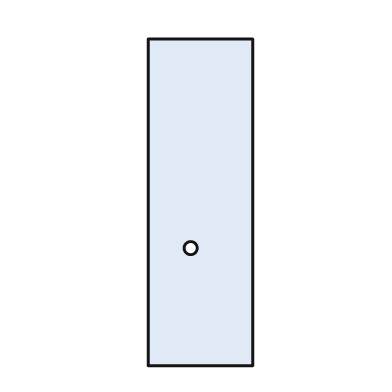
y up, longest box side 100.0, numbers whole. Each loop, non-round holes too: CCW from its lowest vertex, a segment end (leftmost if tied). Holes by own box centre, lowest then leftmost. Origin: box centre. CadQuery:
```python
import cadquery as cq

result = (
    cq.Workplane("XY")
    .moveTo(-16.0, -50.0)
    .lineTo(16.0, -50.0)
    .lineTo(16.0, 50.0)
    .lineTo(-16.0, 50.0)
    .close()
    .moveTo(-3.0, -14.0)
    .circle(2.0)
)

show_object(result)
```